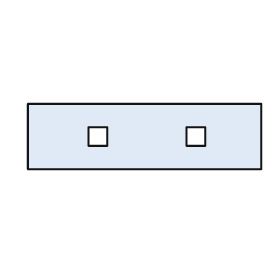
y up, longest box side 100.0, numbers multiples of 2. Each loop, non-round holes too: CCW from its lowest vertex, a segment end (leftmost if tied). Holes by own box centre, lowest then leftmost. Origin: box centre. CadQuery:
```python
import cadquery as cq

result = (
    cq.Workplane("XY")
    .moveTo(-50.0, -14.0)
    .lineTo(50.0, -14.0)
    .lineTo(50.0, 14.0)
    .lineTo(-50.0, 14.0)
    .close()
    .moveTo(-24.0, -4.0)
    .lineTo(-16.0, -4.0)
    .lineTo(-16.0, 4.0)
    .lineTo(-24.0, 4.0)
    .close()
    .moveTo(18.0, -4.0)
    .lineTo(26.0, -4.0)
    .lineTo(26.0, 4.0)
    .lineTo(18.0, 4.0)
    .close()
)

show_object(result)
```